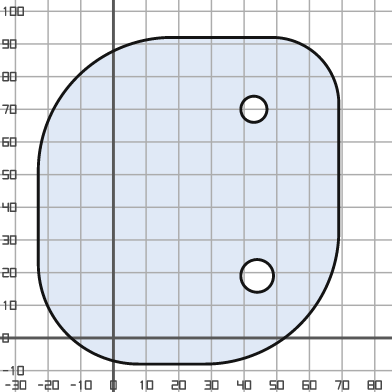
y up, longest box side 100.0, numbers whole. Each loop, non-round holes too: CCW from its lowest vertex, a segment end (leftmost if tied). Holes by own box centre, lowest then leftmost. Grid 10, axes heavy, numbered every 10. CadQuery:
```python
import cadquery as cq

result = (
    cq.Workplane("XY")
    .moveTo(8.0, -8.0)
    .lineTo(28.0, -8.0)
    .threePointArc((57.0, 4.0), (69.0, 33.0))
    .lineTo(69.0, 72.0)
    .threePointArc((63.0, 86.0), (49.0, 92.0))
    .lineTo(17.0, 92.0)
    .threePointArc((-11.0, 80.0), (-23.0, 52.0))
    .lineTo(-23.0, 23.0)
    .threePointArc((-14.0, 1.0), (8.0, -8.0))
    .close()
    .moveTo(44.0, 19.0)
    .circle(5.0)
    .moveTo(43.0, 70.0)
    .circle(4.0)
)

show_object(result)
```